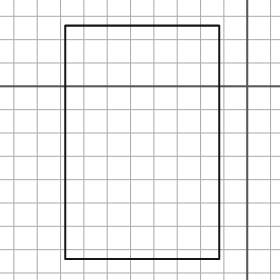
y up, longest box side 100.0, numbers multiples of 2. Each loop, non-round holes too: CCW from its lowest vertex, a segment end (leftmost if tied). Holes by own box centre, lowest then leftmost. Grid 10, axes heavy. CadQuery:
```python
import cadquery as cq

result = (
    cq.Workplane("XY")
    .moveTo(-78.0, -74.0)
    .lineTo(-12.0, -74.0)
    .lineTo(-12.0, 26.0)
    .lineTo(-78.0, 26.0)
    .close()
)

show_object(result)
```